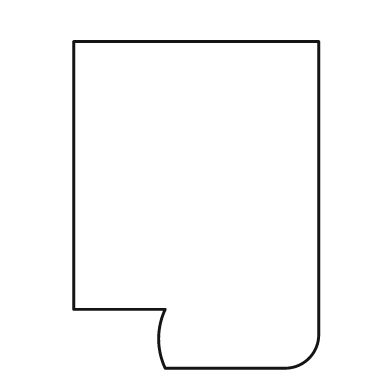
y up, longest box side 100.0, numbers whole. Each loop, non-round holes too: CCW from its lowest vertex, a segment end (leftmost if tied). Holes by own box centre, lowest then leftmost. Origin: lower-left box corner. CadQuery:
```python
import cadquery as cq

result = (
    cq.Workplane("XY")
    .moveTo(28.0, 0.0)
    .lineTo(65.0, 0.0)
    .threePointArc((72.0, 3.0), (75.0, 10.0))
    .lineTo(75.0, 100.0)
    .lineTo(0.0, 100.0)
    .lineTo(0.0, 18.0)
    .lineTo(28.0, 18.0)
    .threePointArc((26.0, 9.0), (28.0, 0.0))
    .close()
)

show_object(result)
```